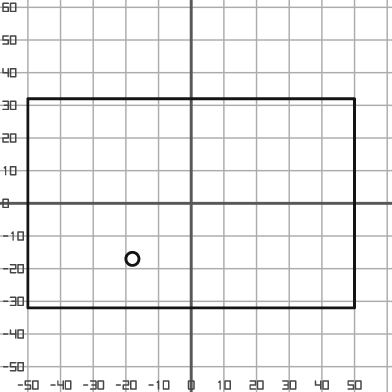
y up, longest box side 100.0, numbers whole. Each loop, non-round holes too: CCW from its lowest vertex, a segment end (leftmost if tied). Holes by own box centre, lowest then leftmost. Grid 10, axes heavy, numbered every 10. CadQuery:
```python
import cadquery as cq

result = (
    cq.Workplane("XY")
    .moveTo(-50.0, -32.0)
    .lineTo(50.0, -32.0)
    .lineTo(50.0, 32.0)
    .lineTo(-50.0, 32.0)
    .close()
    .moveTo(-18.0, -17.0)
    .circle(2.0)
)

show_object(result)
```